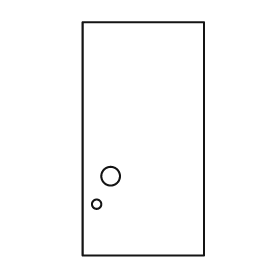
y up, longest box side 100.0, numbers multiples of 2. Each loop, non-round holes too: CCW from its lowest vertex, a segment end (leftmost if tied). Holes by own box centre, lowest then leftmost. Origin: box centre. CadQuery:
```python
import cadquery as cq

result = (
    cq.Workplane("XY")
    .moveTo(-26.0, -50.0)
    .lineTo(26.0, -50.0)
    .lineTo(26.0, 50.0)
    .lineTo(-26.0, 50.0)
    .close()
    .moveTo(-20.0, -28.0)
    .circle(2.0)
    .moveTo(-14.0, -16.0)
    .circle(4.0)
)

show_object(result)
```